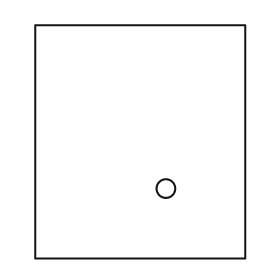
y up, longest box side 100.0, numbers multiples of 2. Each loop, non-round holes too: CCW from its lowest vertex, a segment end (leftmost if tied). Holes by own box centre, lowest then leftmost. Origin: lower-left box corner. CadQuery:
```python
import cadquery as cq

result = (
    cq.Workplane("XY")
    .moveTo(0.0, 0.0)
    .lineTo(90.0, 0.0)
    .lineTo(90.0, 100.0)
    .lineTo(0.0, 100.0)
    .close()
    .moveTo(56.0, 30.0)
    .circle(4.0)
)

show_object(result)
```